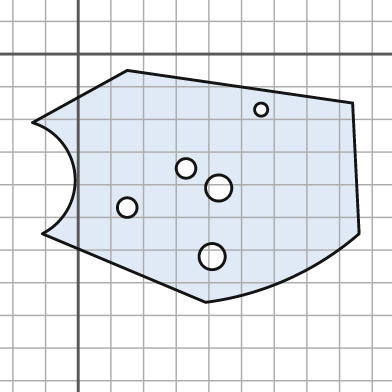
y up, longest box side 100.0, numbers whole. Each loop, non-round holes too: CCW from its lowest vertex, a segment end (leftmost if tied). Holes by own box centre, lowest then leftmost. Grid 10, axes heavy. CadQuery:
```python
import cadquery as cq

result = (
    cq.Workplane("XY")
    .moveTo(39.0, -76.0)
    .threePointArc((64.0, -69.0), (86.0, -55.0))
    .lineTo(84.0, -15.0)
    .lineTo(15.0, -5.0)
    .lineTo(-14.0, -21.0)
    .threePointArc((-1.0, -37.0), (-11.0, -55.0))
    .close()
    .moveTo(41.0, -62.0)
    .circle(4.0)
    .moveTo(15.0, -47.0)
    .circle(3.0)
    .moveTo(43.0, -41.0)
    .circle(4.0)
    .moveTo(33.0, -35.0)
    .circle(3.0)
    .moveTo(56.0, -17.0)
    .circle(2.0)
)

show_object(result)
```